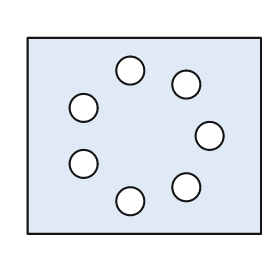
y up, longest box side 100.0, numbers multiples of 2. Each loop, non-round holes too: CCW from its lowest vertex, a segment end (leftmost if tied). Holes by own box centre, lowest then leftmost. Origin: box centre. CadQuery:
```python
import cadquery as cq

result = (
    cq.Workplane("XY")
    .moveTo(-50.0, -42.0)
    .lineTo(50.0, -42.0)
    .lineTo(50.0, 42.0)
    .lineTo(-50.0, 42.0)
    .close()
    .moveTo(-6.0, -28.0)
    .circle(6.0)
    .moveTo(18.0, -22.0)
    .circle(6.0)
    .moveTo(-26.0, -12.0)
    .circle(6.0)
    .moveTo(28.0, 0.0)
    .circle(6.0)
    .moveTo(-26.0, 12.0)
    .circle(6.0)
    .moveTo(18.0, 22.0)
    .circle(6.0)
    .moveTo(-6.0, 28.0)
    .circle(6.0)
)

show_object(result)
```